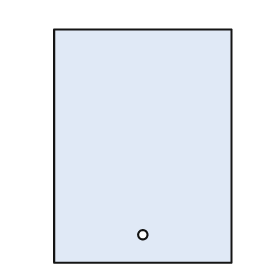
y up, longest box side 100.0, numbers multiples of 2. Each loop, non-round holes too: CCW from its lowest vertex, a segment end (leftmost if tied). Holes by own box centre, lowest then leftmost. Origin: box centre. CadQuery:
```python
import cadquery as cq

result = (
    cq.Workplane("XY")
    .moveTo(-38.0, -50.0)
    .lineTo(38.0, -50.0)
    .lineTo(38.0, 50.0)
    .lineTo(-38.0, 50.0)
    .close()
    .moveTo(0.0, -38.0)
    .circle(2.0)
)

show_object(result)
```